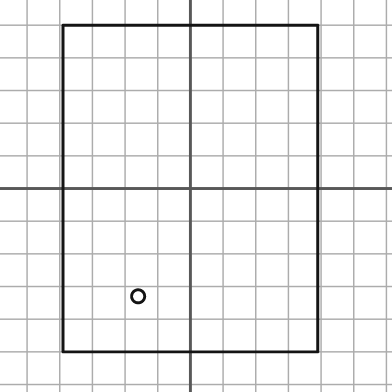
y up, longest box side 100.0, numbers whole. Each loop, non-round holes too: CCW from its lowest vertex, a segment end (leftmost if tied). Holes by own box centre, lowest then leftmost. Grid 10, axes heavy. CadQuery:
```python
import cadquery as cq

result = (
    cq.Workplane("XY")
    .moveTo(-39.0, -50.0)
    .lineTo(39.0, -50.0)
    .lineTo(39.0, 50.0)
    .lineTo(-39.0, 50.0)
    .close()
    .moveTo(-16.0, -33.0)
    .circle(2.0)
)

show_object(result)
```